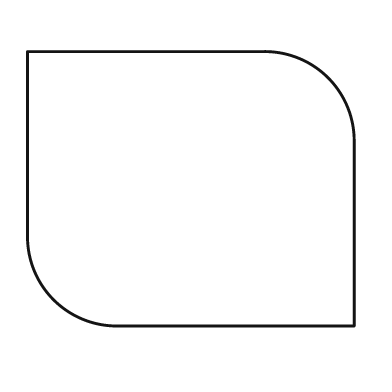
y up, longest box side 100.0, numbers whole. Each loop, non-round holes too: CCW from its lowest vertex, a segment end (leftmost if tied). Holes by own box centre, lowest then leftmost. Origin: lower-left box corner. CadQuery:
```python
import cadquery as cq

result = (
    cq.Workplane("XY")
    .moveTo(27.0, 0.0)
    .lineTo(100.0, 0.0)
    .lineTo(100.0, 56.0)
    .threePointArc((92.0, 76.0), (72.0, 84.0))
    .lineTo(0.0, 84.0)
    .lineTo(0.0, 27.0)
    .threePointArc((8.0, 8.0), (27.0, 0.0))
    .close()
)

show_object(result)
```